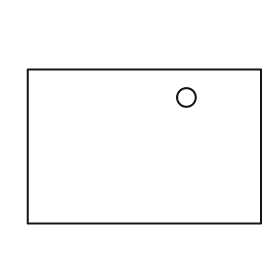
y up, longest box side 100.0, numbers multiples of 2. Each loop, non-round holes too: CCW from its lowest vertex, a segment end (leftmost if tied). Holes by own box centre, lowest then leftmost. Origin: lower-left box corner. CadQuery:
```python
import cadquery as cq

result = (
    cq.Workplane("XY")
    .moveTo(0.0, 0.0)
    .lineTo(100.0, 0.0)
    .lineTo(100.0, 66.0)
    .lineTo(0.0, 66.0)
    .close()
    .moveTo(68.0, 54.0)
    .circle(4.0)
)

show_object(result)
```